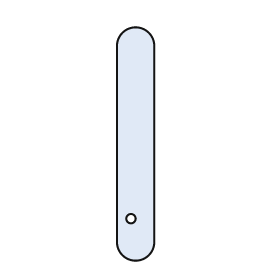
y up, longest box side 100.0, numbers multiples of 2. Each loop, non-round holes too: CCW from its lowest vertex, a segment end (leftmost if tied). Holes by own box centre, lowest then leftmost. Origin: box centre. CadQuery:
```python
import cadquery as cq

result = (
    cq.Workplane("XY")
    .moveTo(-8.0, -42.0)
    .threePointArc((0.0, -50.0), (8.0, -42.0))
    .lineTo(8.0, 42.0)
    .threePointArc((0.0, 50.0), (-8.0, 42.0))
    .close()
    .moveTo(-2.0, -32.0)
    .circle(2.0)
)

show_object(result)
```